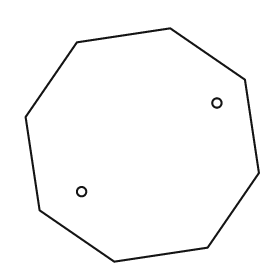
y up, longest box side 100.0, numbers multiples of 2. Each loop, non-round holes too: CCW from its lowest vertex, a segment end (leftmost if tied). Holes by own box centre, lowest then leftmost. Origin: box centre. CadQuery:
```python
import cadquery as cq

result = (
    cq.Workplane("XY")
    .moveTo(-12.0, -50.0)
    .lineTo(28.0, -44.0)
    .lineTo(50.0, -12.0)
    .lineTo(44.0, 28.0)
    .lineTo(12.0, 50.0)
    .lineTo(-28.0, 44.0)
    .lineTo(-50.0, 12.0)
    .lineTo(-44.0, -28.0)
    .close()
    .moveTo(-26.0, -20.0)
    .circle(2.0)
    .moveTo(32.0, 18.0)
    .circle(2.0)
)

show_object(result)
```